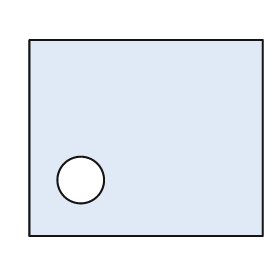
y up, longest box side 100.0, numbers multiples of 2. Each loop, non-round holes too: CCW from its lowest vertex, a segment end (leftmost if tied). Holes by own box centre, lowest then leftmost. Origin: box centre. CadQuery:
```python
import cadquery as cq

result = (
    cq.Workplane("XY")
    .moveTo(-50.0, -42.0)
    .lineTo(50.0, -42.0)
    .lineTo(50.0, 42.0)
    .lineTo(-50.0, 42.0)
    .close()
    .moveTo(-28.0, -18.0)
    .circle(10.0)
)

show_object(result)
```